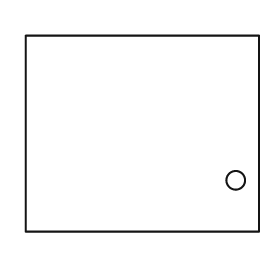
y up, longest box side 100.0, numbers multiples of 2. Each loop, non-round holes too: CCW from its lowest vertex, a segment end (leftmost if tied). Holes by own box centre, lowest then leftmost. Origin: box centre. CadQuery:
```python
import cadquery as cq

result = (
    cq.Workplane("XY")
    .moveTo(-50.0, -42.0)
    .lineTo(50.0, -42.0)
    .lineTo(50.0, 42.0)
    .lineTo(-50.0, 42.0)
    .close()
    .moveTo(40.0, -20.0)
    .circle(4.0)
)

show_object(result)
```